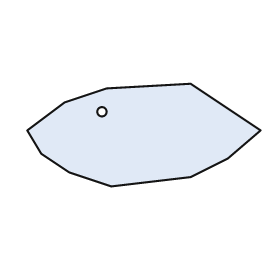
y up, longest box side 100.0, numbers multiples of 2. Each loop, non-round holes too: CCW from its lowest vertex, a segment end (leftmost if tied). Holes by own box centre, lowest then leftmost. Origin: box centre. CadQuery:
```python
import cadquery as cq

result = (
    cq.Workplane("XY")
    .moveTo(-14.0, -22.0)
    .lineTo(20.0, -18.0)
    .lineTo(36.0, -10.0)
    .lineTo(50.0, 2.0)
    .lineTo(20.0, 22.0)
    .lineTo(-16.0, 20.0)
    .lineTo(-34.0, 14.0)
    .lineTo(-50.0, 2.0)
    .lineTo(-44.0, -8.0)
    .lineTo(-32.0, -16.0)
    .close()
    .moveTo(-18.0, 10.0)
    .circle(2.0)
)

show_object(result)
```